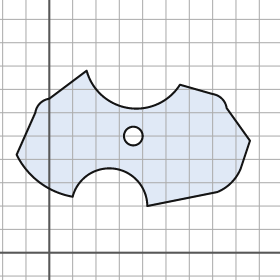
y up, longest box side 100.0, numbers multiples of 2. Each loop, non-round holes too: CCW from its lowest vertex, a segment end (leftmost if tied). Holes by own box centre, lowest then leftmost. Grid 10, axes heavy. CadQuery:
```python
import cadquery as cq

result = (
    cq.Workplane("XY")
    .moveTo(42.0, 20.0)
    .lineTo(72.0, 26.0)
    .threePointArc((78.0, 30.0), (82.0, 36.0))
    .lineTo(86.0, 48.0)
    .lineTo(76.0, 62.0)
    .threePointArc((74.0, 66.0), (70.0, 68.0))
    .lineTo(56.0, 72.0)
    .threePointArc((34.0, 62.0), (16.0, 78.0))
    .lineTo(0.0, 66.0)
    .threePointArc((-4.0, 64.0), (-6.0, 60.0))
    .lineTo(-14.0, 42.0)
    .threePointArc((-4.0, 30.0), (10.0, 24.0))
    .threePointArc((28.0, 36.0), (42.0, 20.0))
    .close()
    .moveTo(36.0, 50.0)
    .circle(4.0)
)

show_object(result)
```